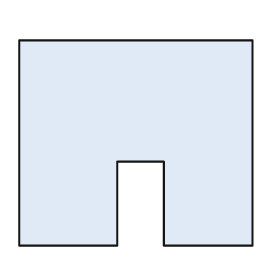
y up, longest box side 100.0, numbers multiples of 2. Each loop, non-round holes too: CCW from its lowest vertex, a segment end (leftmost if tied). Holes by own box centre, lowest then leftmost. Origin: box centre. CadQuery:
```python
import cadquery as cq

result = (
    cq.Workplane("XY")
    .moveTo(-50.0, -44.0)
    .lineTo(-8.0, -44.0)
    .lineTo(-8.0, -8.0)
    .lineTo(12.0, -8.0)
    .lineTo(12.0, -44.0)
    .lineTo(50.0, -44.0)
    .lineTo(50.0, 44.0)
    .lineTo(-50.0, 44.0)
    .close()
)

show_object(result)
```